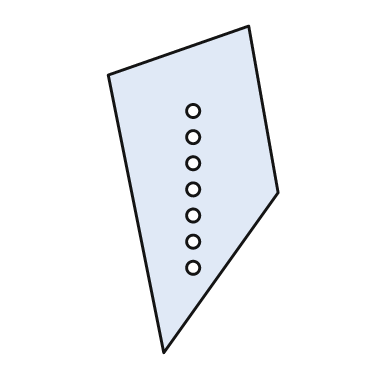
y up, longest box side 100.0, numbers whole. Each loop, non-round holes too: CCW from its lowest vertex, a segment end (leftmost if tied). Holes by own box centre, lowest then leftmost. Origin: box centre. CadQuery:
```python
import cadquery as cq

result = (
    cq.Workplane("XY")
    .moveTo(-9.0, -50.0)
    .lineTo(26.0, -1.0)
    .lineTo(17.0, 50.0)
    .lineTo(-26.0, 35.0)
    .close()
    .moveTo(0.0, -24.0)
    .circle(2.0)
    .moveTo(0.0, -16.0)
    .circle(2.0)
    .moveTo(0.0, -8.0)
    .circle(2.0)
    .moveTo(0.0, 0.0)
    .circle(2.0)
    .moveTo(0.0, 8.0)
    .circle(2.0)
    .moveTo(0.0, 16.0)
    .circle(2.0)
    .moveTo(0.0, 24.0)
    .circle(2.0)
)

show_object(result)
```